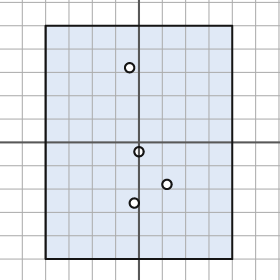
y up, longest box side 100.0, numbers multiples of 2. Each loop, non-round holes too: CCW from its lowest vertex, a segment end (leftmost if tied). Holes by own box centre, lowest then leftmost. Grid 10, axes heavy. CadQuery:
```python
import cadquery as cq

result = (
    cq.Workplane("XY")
    .moveTo(-40.0, -50.0)
    .lineTo(40.0, -50.0)
    .lineTo(40.0, 50.0)
    .lineTo(-40.0, 50.0)
    .close()
    .moveTo(-2.0, -26.0)
    .circle(2.0)
    .moveTo(12.0, -18.0)
    .circle(2.0)
    .moveTo(0.0, -4.0)
    .circle(2.0)
    .moveTo(-4.0, 32.0)
    .circle(2.0)
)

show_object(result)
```